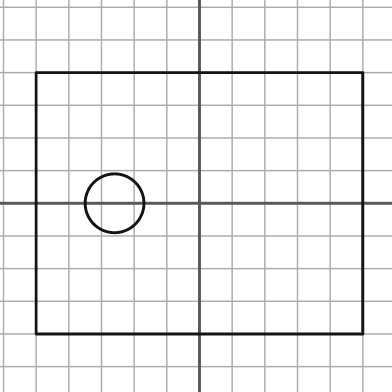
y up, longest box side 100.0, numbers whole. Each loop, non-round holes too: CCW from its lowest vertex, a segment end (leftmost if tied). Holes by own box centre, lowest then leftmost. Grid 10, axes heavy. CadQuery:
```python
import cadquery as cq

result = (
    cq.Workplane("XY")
    .moveTo(-50.0, -40.0)
    .lineTo(50.0, -40.0)
    .lineTo(50.0, 40.0)
    .lineTo(-50.0, 40.0)
    .close()
    .moveTo(-26.0, 0.0)
    .circle(9.0)
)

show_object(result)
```